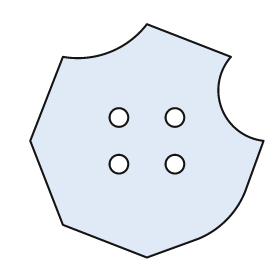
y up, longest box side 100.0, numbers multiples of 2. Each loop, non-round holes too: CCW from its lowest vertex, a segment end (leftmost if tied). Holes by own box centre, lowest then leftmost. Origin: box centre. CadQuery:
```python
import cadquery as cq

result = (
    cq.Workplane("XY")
    .moveTo(0.0, -50.0)
    .lineTo(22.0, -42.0)
    .threePointArc((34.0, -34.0), (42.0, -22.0))
    .lineTo(50.0, 0.0)
    .threePointArc((32.0, 14.0), (36.0, 36.0))
    .lineTo(0.0, 50.0)
    .threePointArc((-16.0, 38.0), (-36.0, 36.0))
    .lineTo(-50.0, 0.0)
    .lineTo(-36.0, -36.0)
    .close()
    .moveTo(-12.0, -10.0)
    .circle(4.0)
    .moveTo(12.0, -10.0)
    .circle(4.0)
    .moveTo(-12.0, 10.0)
    .circle(4.0)
    .moveTo(12.0, 10.0)
    .circle(4.0)
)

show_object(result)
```